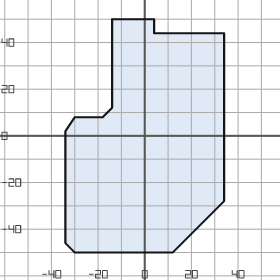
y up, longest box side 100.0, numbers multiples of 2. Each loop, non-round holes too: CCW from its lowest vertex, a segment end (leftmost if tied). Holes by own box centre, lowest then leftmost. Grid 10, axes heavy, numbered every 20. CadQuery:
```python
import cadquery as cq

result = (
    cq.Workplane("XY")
    .moveTo(-30.0, -50.0)
    .lineTo(12.0, -50.0)
    .lineTo(34.0, -28.0)
    .lineTo(34.0, 44.0)
    .lineTo(4.0, 44.0)
    .lineTo(4.0, 50.0)
    .lineTo(-14.0, 50.0)
    .lineTo(-14.0, 12.0)
    .lineTo(-18.0, 8.0)
    .lineTo(-30.0, 8.0)
    .lineTo(-34.0, 2.0)
    .lineTo(-34.0, -46.0)
    .close()
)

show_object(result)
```